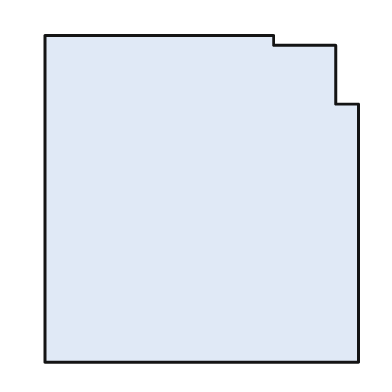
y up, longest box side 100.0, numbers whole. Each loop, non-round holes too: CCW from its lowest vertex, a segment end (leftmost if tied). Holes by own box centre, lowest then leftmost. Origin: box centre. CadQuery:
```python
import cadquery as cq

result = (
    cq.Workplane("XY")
    .moveTo(-48.0, -50.0)
    .lineTo(48.0, -50.0)
    .lineTo(48.0, 29.0)
    .lineTo(41.0, 29.0)
    .lineTo(41.0, 47.0)
    .lineTo(22.0, 47.0)
    .lineTo(22.0, 50.0)
    .lineTo(-48.0, 50.0)
    .close()
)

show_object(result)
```